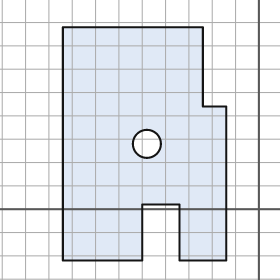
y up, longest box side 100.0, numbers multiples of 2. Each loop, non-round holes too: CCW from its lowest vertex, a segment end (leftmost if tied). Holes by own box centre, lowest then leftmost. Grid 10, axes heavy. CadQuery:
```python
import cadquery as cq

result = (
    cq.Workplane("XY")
    .moveTo(-84.0, -22.0)
    .lineTo(-50.0, -22.0)
    .lineTo(-50.0, 2.0)
    .lineTo(-34.0, 2.0)
    .lineTo(-34.0, -22.0)
    .lineTo(-14.0, -22.0)
    .lineTo(-14.0, 44.0)
    .lineTo(-24.0, 44.0)
    .lineTo(-24.0, 78.0)
    .lineTo(-84.0, 78.0)
    .close()
    .moveTo(-48.0, 28.0)
    .circle(6.0)
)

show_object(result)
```